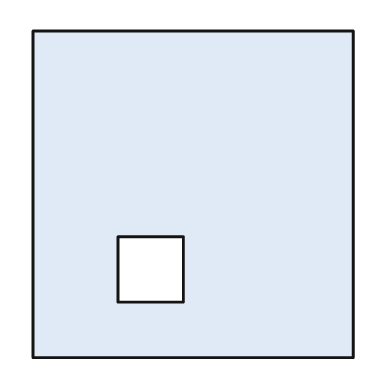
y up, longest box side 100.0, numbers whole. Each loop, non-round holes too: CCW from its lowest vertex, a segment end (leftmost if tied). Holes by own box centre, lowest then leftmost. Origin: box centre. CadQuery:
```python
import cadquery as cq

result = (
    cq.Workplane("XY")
    .moveTo(-49.0, -50.0)
    .lineTo(49.0, -50.0)
    .lineTo(49.0, 50.0)
    .lineTo(-49.0, 50.0)
    .close()
    .moveTo(-23.0, -33.0)
    .lineTo(-3.0, -33.0)
    .lineTo(-3.0, -13.0)
    .lineTo(-23.0, -13.0)
    .close()
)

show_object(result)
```